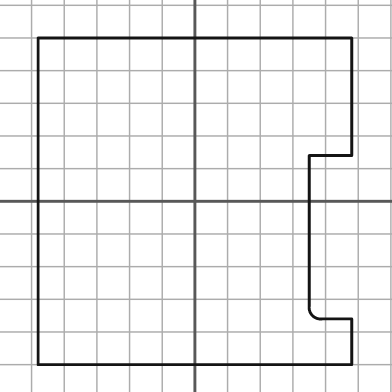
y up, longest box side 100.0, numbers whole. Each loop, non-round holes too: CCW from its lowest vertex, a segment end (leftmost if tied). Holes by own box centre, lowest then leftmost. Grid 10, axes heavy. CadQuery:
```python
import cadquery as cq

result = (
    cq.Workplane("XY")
    .moveTo(-48.0, -50.0)
    .lineTo(48.0, -50.0)
    .lineTo(48.0, -36.0)
    .lineTo(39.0, -36.0)
    .threePointArc((36.0, -35.0), (35.0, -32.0))
    .lineTo(35.0, 14.0)
    .lineTo(48.0, 14.0)
    .lineTo(48.0, 50.0)
    .lineTo(-48.0, 50.0)
    .close()
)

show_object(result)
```